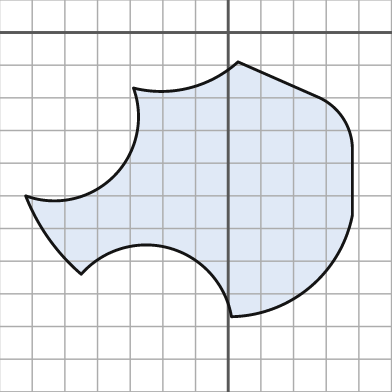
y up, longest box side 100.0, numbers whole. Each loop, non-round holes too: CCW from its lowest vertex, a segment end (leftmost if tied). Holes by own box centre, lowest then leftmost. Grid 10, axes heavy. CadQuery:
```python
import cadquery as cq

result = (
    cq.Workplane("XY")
    .moveTo(1.0, -87.0)
    .threePointArc((25.0, -78.0), (38.0, -56.0))
    .lineTo(38.0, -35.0)
    .threePointArc((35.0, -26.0), (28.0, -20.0))
    .lineTo(3.0, -9.0)
    .threePointArc((-12.0, -17.0), (-29.0, -17.0))
    .threePointArc((-35.0, -44.0), (-62.0, -50.0))
    .threePointArc((-55.0, -63.0), (-45.0, -74.0))
    .threePointArc((-18.0, -66.0), (1.0, -87.0))
    .close()
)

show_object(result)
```